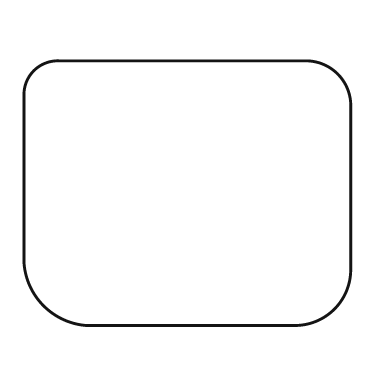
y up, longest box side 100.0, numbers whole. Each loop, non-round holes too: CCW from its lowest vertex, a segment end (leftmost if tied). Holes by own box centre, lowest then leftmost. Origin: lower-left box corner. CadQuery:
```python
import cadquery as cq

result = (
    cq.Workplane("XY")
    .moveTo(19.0, 0.0)
    .lineTo(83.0, 0.0)
    .threePointArc((95.0, 5.0), (100.0, 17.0))
    .lineTo(100.0, 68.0)
    .threePointArc((96.0, 77.0), (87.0, 81.0))
    .lineTo(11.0, 81.0)
    .threePointArc((3.0, 78.0), (0.0, 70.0))
    .lineTo(0.0, 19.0)
    .threePointArc((6.0, 6.0), (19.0, 0.0))
    .close()
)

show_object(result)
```